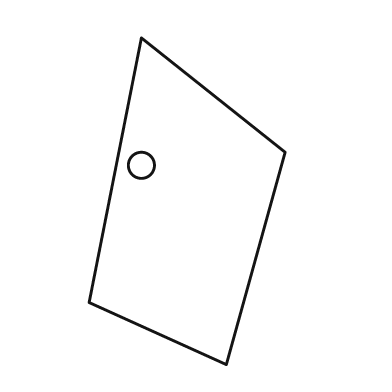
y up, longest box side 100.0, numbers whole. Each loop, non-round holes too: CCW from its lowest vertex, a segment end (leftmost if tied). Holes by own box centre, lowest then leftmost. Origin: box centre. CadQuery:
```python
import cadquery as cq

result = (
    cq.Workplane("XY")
    .moveTo(12.0, -50.0)
    .lineTo(30.0, 15.0)
    .lineTo(-14.0, 50.0)
    .lineTo(-30.0, -31.0)
    .close()
    .moveTo(-14.0, 11.0)
    .circle(4.0)
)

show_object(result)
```